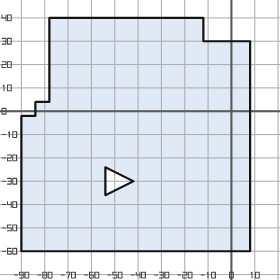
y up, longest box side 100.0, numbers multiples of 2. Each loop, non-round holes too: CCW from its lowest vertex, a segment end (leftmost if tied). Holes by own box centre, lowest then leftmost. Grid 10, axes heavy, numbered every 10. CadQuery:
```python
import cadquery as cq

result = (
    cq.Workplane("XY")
    .moveTo(-90.0, -60.0)
    .lineTo(8.0, -60.0)
    .lineTo(8.0, 30.0)
    .lineTo(-12.0, 30.0)
    .lineTo(-12.0, 40.0)
    .lineTo(-78.0, 40.0)
    .lineTo(-78.0, 4.0)
    .lineTo(-84.0, 4.0)
    .lineTo(-84.0, -2.0)
    .lineTo(-90.0, -2.0)
    .close()
    .moveTo(-54.0, -36.0)
    .lineTo(-42.0, -30.0)
    .lineTo(-54.0, -24.0)
    .close()
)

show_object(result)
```